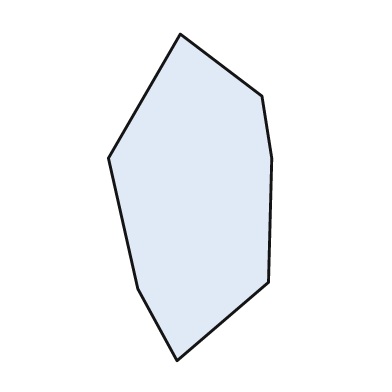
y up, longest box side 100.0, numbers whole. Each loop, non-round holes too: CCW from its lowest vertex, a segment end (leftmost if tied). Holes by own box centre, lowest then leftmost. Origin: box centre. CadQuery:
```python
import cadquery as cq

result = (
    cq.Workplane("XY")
    .moveTo(-4.0, -50.0)
    .lineTo(24.0, -26.0)
    .lineTo(25.0, 12.0)
    .lineTo(22.0, 31.0)
    .lineTo(-3.0, 50.0)
    .lineTo(-25.0, 12.0)
    .lineTo(-16.0, -28.0)
    .close()
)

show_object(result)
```